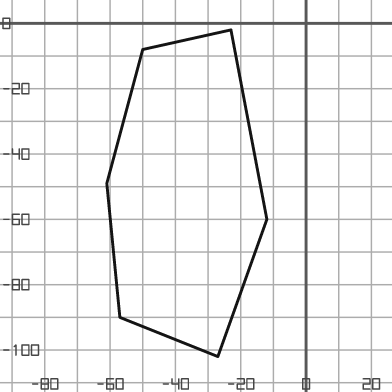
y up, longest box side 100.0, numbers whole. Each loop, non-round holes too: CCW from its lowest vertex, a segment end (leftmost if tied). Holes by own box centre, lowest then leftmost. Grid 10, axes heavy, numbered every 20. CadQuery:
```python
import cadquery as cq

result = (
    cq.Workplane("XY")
    .moveTo(-27.0, -102.0)
    .lineTo(-12.0, -60.0)
    .lineTo(-23.0, -2.0)
    .lineTo(-50.0, -8.0)
    .lineTo(-61.0, -49.0)
    .lineTo(-57.0, -90.0)
    .close()
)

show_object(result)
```